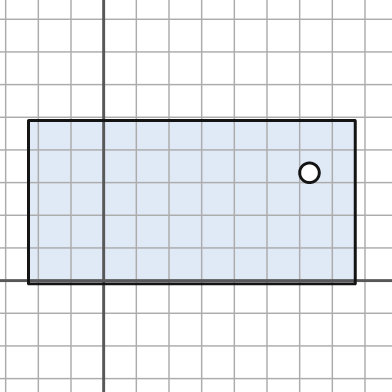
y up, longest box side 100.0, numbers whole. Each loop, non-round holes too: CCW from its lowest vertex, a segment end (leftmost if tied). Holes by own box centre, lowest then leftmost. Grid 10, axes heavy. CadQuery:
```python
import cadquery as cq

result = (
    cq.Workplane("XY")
    .moveTo(-23.0, -1.0)
    .lineTo(77.0, -1.0)
    .lineTo(77.0, 49.0)
    .lineTo(-23.0, 49.0)
    .close()
    .moveTo(63.0, 33.0)
    .circle(3.0)
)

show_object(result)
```